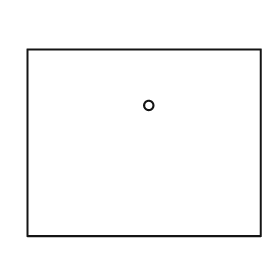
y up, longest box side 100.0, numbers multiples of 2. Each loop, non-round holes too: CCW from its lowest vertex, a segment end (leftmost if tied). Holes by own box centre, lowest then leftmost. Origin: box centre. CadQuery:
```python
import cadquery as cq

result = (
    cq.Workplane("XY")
    .moveTo(-50.0, -40.0)
    .lineTo(50.0, -40.0)
    .lineTo(50.0, 40.0)
    .lineTo(-50.0, 40.0)
    .close()
    .moveTo(2.0, 16.0)
    .circle(2.0)
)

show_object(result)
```